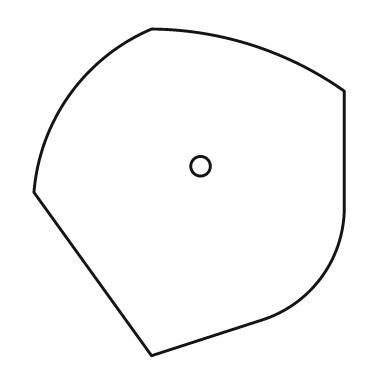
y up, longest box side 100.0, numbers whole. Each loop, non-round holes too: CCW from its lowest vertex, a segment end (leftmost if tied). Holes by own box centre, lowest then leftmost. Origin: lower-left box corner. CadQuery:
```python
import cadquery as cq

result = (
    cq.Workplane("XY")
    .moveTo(36.0, 0.0)
    .lineTo(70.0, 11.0)
    .threePointArc((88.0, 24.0), (95.0, 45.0))
    .lineTo(95.0, 81.0)
    .threePointArc((67.0, 95.0), (36.0, 100.0))
    .threePointArc((11.0, 80.0), (0.0, 50.0))
    .close()
    .moveTo(51.0, 58.0)
    .circle(3.0)
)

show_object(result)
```